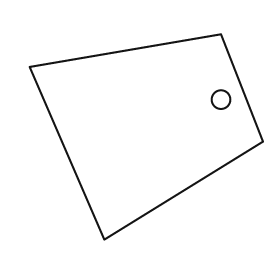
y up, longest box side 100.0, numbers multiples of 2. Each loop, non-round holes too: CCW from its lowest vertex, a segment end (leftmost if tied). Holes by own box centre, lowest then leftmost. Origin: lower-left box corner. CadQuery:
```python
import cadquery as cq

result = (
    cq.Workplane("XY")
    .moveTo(32.0, 0.0)
    .lineTo(100.0, 42.0)
    .lineTo(82.0, 88.0)
    .lineTo(0.0, 74.0)
    .close()
    .moveTo(82.0, 60.0)
    .circle(4.0)
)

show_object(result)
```